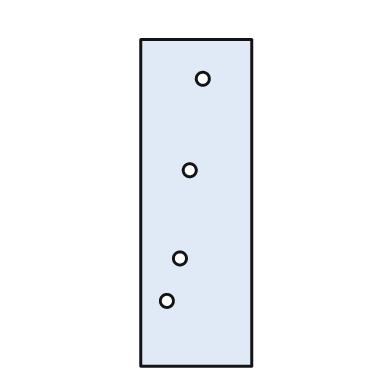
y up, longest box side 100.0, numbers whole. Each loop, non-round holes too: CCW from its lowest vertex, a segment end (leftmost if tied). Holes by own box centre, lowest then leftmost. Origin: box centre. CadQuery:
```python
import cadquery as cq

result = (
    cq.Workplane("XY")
    .moveTo(-17.0, -50.0)
    .lineTo(17.0, -50.0)
    .lineTo(17.0, 50.0)
    .lineTo(-17.0, 50.0)
    .close()
    .moveTo(-9.0, -30.0)
    .circle(2.0)
    .moveTo(-5.0, -17.0)
    .circle(2.0)
    .moveTo(-2.0, 10.0)
    .circle(2.0)
    .moveTo(2.0, 38.0)
    .circle(2.0)
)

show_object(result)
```